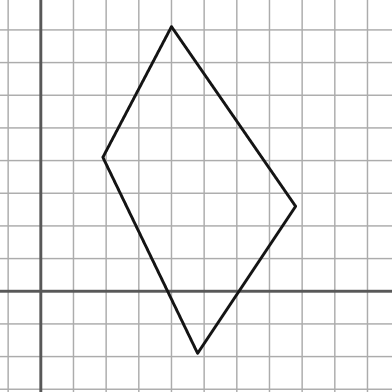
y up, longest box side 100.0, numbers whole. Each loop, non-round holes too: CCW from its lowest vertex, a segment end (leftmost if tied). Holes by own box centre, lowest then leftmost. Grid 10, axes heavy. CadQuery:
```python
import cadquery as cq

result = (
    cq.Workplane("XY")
    .moveTo(48.0, -19.0)
    .lineTo(78.0, 26.0)
    .lineTo(40.0, 81.0)
    .lineTo(19.0, 41.0)
    .close()
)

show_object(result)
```